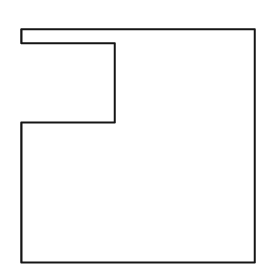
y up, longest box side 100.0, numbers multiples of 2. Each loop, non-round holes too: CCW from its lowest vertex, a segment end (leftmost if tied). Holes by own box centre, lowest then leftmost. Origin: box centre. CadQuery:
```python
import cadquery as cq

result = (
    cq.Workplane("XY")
    .moveTo(-50.0, -50.0)
    .lineTo(50.0, -50.0)
    .lineTo(50.0, 50.0)
    .lineTo(-50.0, 50.0)
    .lineTo(-50.0, 44.0)
    .lineTo(-10.0, 44.0)
    .lineTo(-10.0, 10.0)
    .lineTo(-50.0, 10.0)
    .close()
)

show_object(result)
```